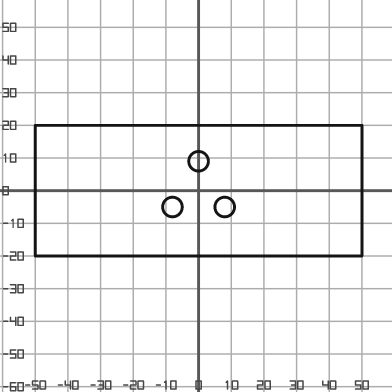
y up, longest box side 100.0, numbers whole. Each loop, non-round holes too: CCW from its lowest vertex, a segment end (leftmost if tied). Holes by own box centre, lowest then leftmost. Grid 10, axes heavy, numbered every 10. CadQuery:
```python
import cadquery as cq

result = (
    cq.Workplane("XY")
    .moveTo(-50.0, -20.0)
    .lineTo(50.0, -20.0)
    .lineTo(50.0, 20.0)
    .lineTo(-50.0, 20.0)
    .close()
    .moveTo(-8.0, -5.0)
    .circle(3.0)
    .moveTo(8.0, -5.0)
    .circle(3.0)
    .moveTo(0.0, 9.0)
    .circle(3.0)
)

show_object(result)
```